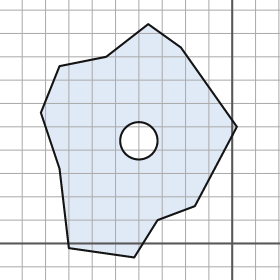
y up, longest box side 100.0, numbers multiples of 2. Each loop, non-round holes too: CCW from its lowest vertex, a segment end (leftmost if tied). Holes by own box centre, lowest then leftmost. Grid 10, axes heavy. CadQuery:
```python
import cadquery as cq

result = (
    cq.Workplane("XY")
    .moveTo(-42.0, -6.0)
    .lineTo(-32.0, 10.0)
    .lineTo(-16.0, 16.0)
    .lineTo(2.0, 50.0)
    .lineTo(-22.0, 84.0)
    .lineTo(-36.0, 94.0)
    .lineTo(-54.0, 80.0)
    .lineTo(-74.0, 76.0)
    .lineTo(-82.0, 56.0)
    .lineTo(-74.0, 32.0)
    .lineTo(-70.0, -2.0)
    .close()
    .moveTo(-40.0, 44.0)
    .circle(8.0)
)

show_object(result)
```